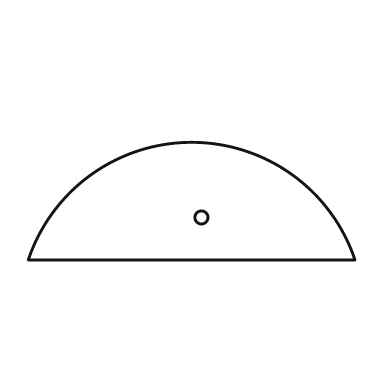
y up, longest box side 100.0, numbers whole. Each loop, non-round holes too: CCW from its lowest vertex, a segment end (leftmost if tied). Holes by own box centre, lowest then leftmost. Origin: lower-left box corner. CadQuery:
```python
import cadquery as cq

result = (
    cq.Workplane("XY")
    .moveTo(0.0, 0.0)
    .lineTo(100.0, 0.0)
    .threePointArc((50.0, 36.0), (0.0, 0.0))
    .close()
    .moveTo(53.0, 13.0)
    .circle(2.0)
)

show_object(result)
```